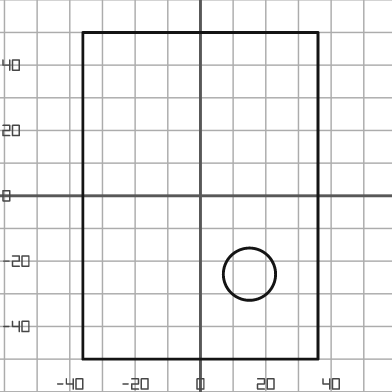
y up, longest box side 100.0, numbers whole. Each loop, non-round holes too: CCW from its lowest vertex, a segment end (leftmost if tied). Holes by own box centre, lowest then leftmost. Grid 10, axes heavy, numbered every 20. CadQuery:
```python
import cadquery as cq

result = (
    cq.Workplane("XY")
    .moveTo(-36.0, -50.0)
    .lineTo(36.0, -50.0)
    .lineTo(36.0, 50.0)
    .lineTo(-36.0, 50.0)
    .close()
    .moveTo(15.0, -24.0)
    .circle(8.0)
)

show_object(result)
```